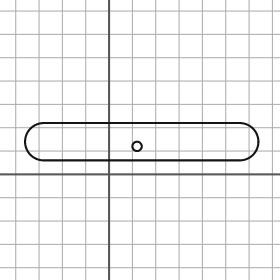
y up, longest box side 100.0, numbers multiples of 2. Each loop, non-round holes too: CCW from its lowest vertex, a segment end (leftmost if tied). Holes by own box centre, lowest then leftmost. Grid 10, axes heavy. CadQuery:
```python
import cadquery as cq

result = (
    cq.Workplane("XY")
    .moveTo(-28.0, 6.0)
    .lineTo(56.0, 6.0)
    .threePointArc((64.0, 14.0), (56.0, 22.0))
    .lineTo(-28.0, 22.0)
    .threePointArc((-36.0, 14.0), (-28.0, 6.0))
    .close()
    .moveTo(12.0, 12.0)
    .circle(2.0)
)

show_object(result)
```